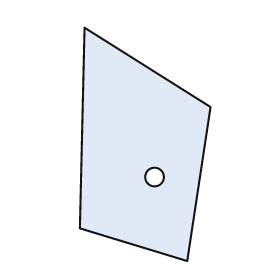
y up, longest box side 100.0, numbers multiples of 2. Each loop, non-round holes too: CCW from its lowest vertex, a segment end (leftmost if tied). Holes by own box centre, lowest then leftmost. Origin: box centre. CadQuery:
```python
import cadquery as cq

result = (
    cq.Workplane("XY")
    .moveTo(18.0, -50.0)
    .lineTo(28.0, 16.0)
    .lineTo(-26.0, 50.0)
    .lineTo(-28.0, -36.0)
    .close()
    .moveTo(4.0, -14.0)
    .circle(4.0)
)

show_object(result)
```